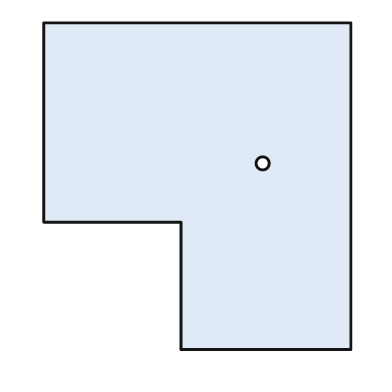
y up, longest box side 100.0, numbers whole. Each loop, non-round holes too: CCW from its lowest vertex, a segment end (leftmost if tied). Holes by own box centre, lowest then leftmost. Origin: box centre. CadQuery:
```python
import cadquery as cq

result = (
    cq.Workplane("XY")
    .moveTo(-5.0, -50.0)
    .lineTo(47.0, -50.0)
    .lineTo(47.0, 50.0)
    .lineTo(-47.0, 50.0)
    .lineTo(-47.0, -11.0)
    .lineTo(-5.0, -11.0)
    .close()
    .moveTo(20.0, 7.0)
    .circle(2.0)
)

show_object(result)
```